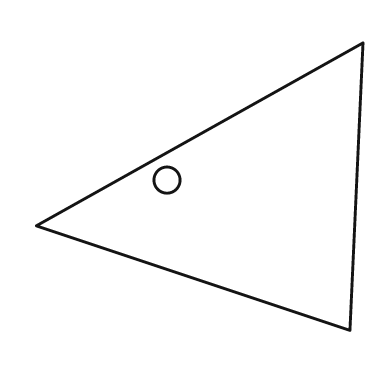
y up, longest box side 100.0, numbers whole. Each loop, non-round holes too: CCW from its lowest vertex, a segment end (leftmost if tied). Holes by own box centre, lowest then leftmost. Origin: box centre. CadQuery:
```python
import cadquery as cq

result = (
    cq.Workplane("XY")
    .moveTo(46.0, -44.0)
    .lineTo(50.0, 44.0)
    .lineTo(-50.0, -12.0)
    .close()
    .moveTo(-10.0, 2.0)
    .circle(4.0)
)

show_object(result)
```